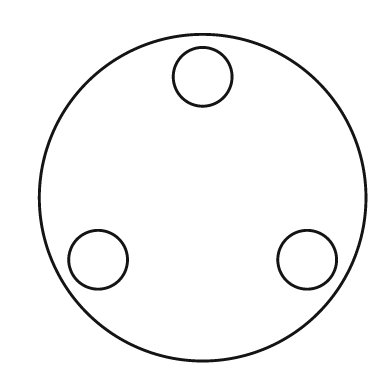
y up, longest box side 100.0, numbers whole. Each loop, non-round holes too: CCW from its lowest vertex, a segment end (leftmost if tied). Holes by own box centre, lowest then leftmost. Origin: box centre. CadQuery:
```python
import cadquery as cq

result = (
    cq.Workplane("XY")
    .moveTo(0.0, 0.0)
    .circle(50.0)
    .moveTo(-32.0, -19.0)
    .circle(9.0)
    .moveTo(32.0, -19.0)
    .circle(9.0)
    .moveTo(0.0, 37.0)
    .circle(9.0)
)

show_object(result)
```